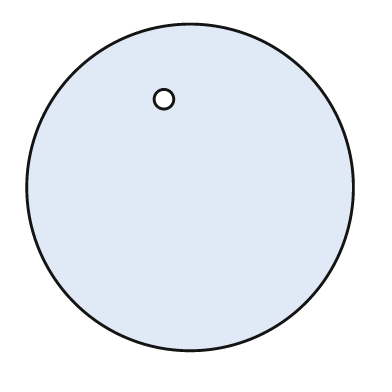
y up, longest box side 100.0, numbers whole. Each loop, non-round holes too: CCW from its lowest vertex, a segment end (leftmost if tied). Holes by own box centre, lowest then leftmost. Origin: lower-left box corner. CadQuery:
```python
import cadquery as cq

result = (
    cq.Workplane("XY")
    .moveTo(50.0, 50.0)
    .circle(50.0)
    .moveTo(42.0, 77.0)
    .circle(3.0)
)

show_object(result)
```